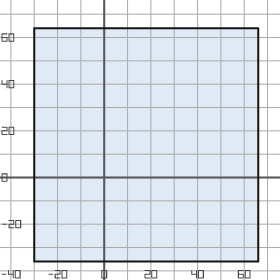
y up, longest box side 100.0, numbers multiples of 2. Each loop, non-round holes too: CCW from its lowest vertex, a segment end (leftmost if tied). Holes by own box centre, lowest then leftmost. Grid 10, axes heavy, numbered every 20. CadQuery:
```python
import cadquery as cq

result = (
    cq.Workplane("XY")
    .moveTo(-30.0, -36.0)
    .lineTo(66.0, -36.0)
    .lineTo(66.0, 64.0)
    .lineTo(-30.0, 64.0)
    .close()
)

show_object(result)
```